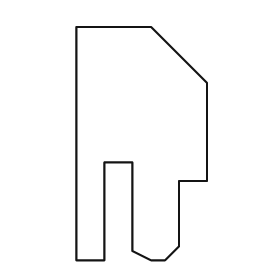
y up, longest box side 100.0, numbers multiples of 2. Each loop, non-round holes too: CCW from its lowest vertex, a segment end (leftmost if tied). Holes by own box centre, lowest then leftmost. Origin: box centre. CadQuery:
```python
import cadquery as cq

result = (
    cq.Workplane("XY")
    .moveTo(-28.0, -50.0)
    .lineTo(-16.0, -50.0)
    .lineTo(-16.0, -8.0)
    .lineTo(-4.0, -8.0)
    .lineTo(-4.0, -46.0)
    .lineTo(4.0, -50.0)
    .lineTo(10.0, -50.0)
    .lineTo(16.0, -44.0)
    .lineTo(16.0, -16.0)
    .lineTo(28.0, -16.0)
    .lineTo(28.0, 26.0)
    .lineTo(4.0, 50.0)
    .lineTo(-28.0, 50.0)
    .close()
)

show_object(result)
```